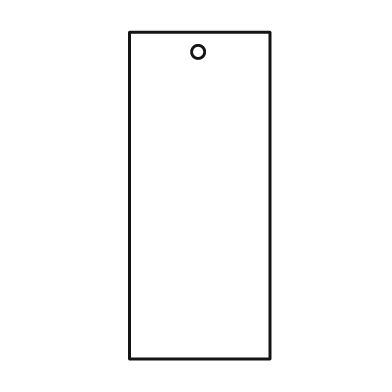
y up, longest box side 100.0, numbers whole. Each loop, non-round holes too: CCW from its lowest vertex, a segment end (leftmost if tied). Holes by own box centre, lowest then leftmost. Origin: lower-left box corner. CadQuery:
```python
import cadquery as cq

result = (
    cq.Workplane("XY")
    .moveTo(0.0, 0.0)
    .lineTo(43.0, 0.0)
    .lineTo(43.0, 100.0)
    .lineTo(0.0, 100.0)
    .close()
    .moveTo(21.0, 94.0)
    .circle(2.0)
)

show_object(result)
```